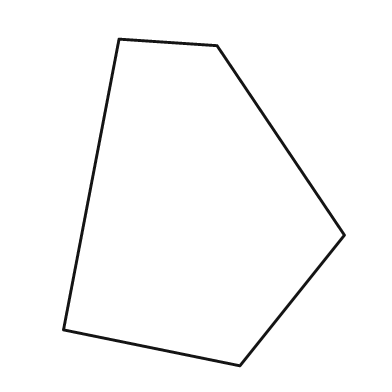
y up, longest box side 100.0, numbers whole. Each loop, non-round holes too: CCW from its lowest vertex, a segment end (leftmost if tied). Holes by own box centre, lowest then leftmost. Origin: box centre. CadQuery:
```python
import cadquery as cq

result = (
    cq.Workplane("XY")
    .moveTo(11.0, -50.0)
    .lineTo(43.0, -10.0)
    .lineTo(4.0, 48.0)
    .lineTo(-26.0, 50.0)
    .lineTo(-43.0, -39.0)
    .close()
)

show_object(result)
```